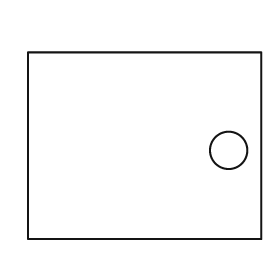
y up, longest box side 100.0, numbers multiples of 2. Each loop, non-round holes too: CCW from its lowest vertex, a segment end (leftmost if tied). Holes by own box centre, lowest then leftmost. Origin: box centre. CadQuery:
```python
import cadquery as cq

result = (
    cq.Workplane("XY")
    .moveTo(-50.0, -40.0)
    .lineTo(50.0, -40.0)
    .lineTo(50.0, 40.0)
    .lineTo(-50.0, 40.0)
    .close()
    .moveTo(36.0, -2.0)
    .circle(8.0)
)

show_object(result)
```